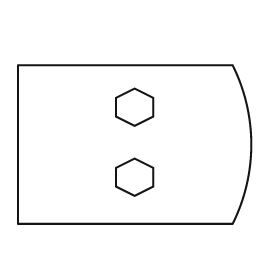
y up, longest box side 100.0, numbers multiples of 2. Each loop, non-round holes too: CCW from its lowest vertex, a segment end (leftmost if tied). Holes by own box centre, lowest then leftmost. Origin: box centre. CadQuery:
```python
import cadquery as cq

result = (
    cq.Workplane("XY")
    .moveTo(-50.0, -34.0)
    .lineTo(42.0, -34.0)
    .threePointArc((50.0, 0.0), (42.0, 34.0))
    .lineTo(-50.0, 34.0)
    .close()
    .moveTo(0.0, -22.0)
    .lineTo(8.0, -18.0)
    .lineTo(8.0, -10.0)
    .lineTo(0.0, -6.0)
    .lineTo(-8.0, -10.0)
    .lineTo(-8.0, -18.0)
    .close()
    .moveTo(0.0, 8.0)
    .lineTo(8.0, 12.0)
    .lineTo(8.0, 20.0)
    .lineTo(0.0, 24.0)
    .lineTo(-8.0, 20.0)
    .lineTo(-8.0, 12.0)
    .close()
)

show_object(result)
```